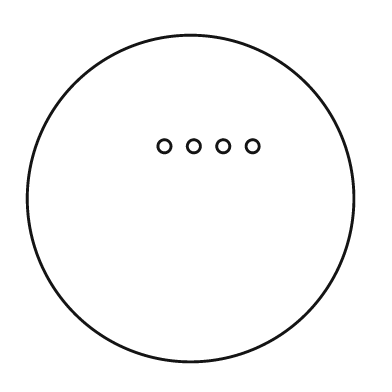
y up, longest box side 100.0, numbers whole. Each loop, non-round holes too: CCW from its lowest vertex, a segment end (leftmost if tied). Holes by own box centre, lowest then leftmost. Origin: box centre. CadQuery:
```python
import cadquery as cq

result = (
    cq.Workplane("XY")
    .moveTo(0.0, 0.0)
    .circle(50.0)
    .moveTo(-8.0, 16.0)
    .circle(2.0)
    .moveTo(1.0, 16.0)
    .circle(2.0)
    .moveTo(10.0, 16.0)
    .circle(2.0)
    .moveTo(19.0, 16.0)
    .circle(2.0)
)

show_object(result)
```